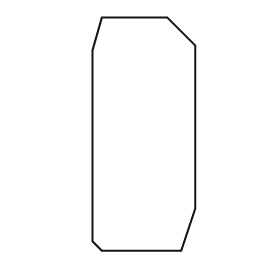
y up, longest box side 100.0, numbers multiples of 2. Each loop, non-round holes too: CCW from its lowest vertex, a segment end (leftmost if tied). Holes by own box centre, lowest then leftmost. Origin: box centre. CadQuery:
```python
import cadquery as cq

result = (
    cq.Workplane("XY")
    .moveTo(-18.0, -50.0)
    .lineTo(16.0, -50.0)
    .lineTo(22.0, -32.0)
    .lineTo(22.0, 38.0)
    .lineTo(10.0, 50.0)
    .lineTo(-18.0, 50.0)
    .lineTo(-22.0, 36.0)
    .lineTo(-22.0, -46.0)
    .close()
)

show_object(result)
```